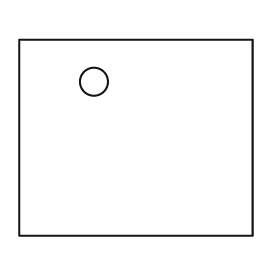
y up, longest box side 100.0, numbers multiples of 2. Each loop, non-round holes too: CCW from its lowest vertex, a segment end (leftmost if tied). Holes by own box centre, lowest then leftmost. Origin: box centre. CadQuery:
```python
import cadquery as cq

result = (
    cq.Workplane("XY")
    .moveTo(-50.0, -42.0)
    .lineTo(50.0, -42.0)
    .lineTo(50.0, 42.0)
    .lineTo(-50.0, 42.0)
    .close()
    .moveTo(-18.0, 24.0)
    .circle(6.0)
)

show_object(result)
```